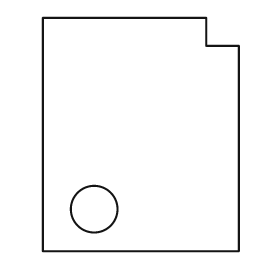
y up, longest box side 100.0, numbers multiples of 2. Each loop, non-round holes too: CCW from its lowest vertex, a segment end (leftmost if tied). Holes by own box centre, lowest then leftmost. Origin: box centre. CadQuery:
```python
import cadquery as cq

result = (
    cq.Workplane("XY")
    .moveTo(-42.0, -50.0)
    .lineTo(42.0, -50.0)
    .lineTo(42.0, 38.0)
    .lineTo(28.0, 38.0)
    .lineTo(28.0, 50.0)
    .lineTo(-42.0, 50.0)
    .close()
    .moveTo(-20.0, -32.0)
    .circle(10.0)
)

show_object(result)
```